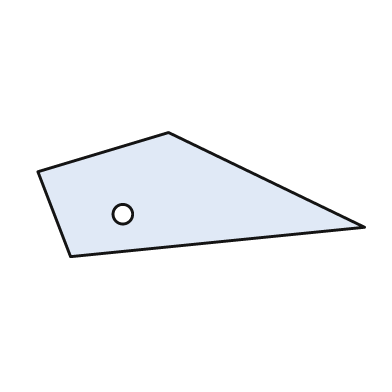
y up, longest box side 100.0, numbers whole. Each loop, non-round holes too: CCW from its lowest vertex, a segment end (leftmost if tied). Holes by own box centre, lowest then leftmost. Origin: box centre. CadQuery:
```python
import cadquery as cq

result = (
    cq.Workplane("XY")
    .moveTo(-40.0, -19.0)
    .lineTo(50.0, -10.0)
    .lineTo(-10.0, 19.0)
    .lineTo(-50.0, 7.0)
    .close()
    .moveTo(-24.0, -6.0)
    .circle(3.0)
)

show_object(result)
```